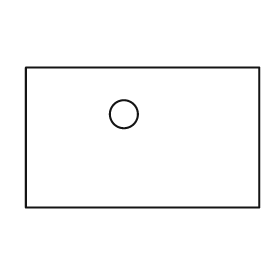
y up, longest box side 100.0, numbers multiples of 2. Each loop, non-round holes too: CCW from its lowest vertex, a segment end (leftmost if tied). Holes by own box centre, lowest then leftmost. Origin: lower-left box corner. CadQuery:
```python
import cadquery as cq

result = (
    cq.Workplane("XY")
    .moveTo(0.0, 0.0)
    .lineTo(100.0, 0.0)
    .lineTo(100.0, 60.0)
    .lineTo(0.0, 60.0)
    .close()
    .moveTo(42.0, 40.0)
    .circle(6.0)
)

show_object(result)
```